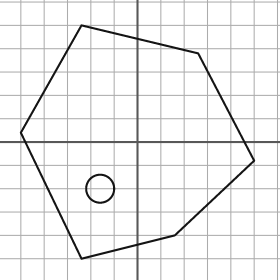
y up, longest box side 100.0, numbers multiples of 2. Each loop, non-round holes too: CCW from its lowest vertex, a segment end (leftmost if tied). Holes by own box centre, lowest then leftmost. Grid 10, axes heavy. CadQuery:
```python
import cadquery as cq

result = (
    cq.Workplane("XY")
    .moveTo(-24.0, -50.0)
    .lineTo(16.0, -40.0)
    .lineTo(50.0, -8.0)
    .lineTo(26.0, 38.0)
    .lineTo(-24.0, 50.0)
    .lineTo(-50.0, 4.0)
    .close()
    .moveTo(-16.0, -20.0)
    .circle(6.0)
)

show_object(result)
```